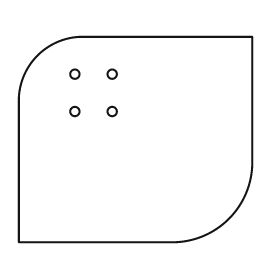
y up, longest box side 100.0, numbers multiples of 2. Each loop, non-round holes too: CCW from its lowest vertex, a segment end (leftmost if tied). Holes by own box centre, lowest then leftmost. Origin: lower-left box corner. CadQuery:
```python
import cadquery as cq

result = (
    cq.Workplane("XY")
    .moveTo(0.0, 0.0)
    .lineTo(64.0, 0.0)
    .threePointArc((90.0, 10.0), (100.0, 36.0))
    .lineTo(100.0, 88.0)
    .lineTo(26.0, 88.0)
    .threePointArc((8.0, 80.0), (0.0, 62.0))
    .close()
    .moveTo(24.0, 56.0)
    .circle(2.0)
    .moveTo(40.0, 56.0)
    .circle(2.0)
    .moveTo(24.0, 72.0)
    .circle(2.0)
    .moveTo(40.0, 72.0)
    .circle(2.0)
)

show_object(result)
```